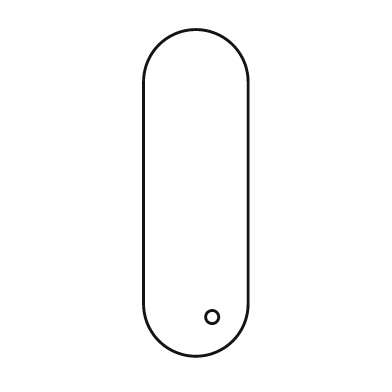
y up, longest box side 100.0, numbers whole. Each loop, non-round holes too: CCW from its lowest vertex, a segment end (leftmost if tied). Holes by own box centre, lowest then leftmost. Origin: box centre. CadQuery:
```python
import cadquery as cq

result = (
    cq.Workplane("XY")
    .moveTo(-16.0, -34.0)
    .threePointArc((0.0, -50.0), (16.0, -34.0))
    .lineTo(16.0, 34.0)
    .threePointArc((0.0, 50.0), (-16.0, 34.0))
    .close()
    .moveTo(5.0, -38.0)
    .circle(2.0)
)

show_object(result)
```